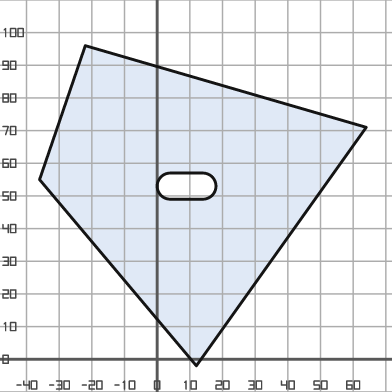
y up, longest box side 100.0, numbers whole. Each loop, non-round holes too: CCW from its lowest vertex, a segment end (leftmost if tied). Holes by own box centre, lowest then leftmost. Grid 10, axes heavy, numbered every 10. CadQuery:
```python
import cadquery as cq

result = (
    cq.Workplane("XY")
    .moveTo(12.0, -2.0)
    .lineTo(64.0, 71.0)
    .lineTo(-22.0, 96.0)
    .lineTo(-36.0, 55.0)
    .close()
    .moveTo(4.0, 49.0)
    .lineTo(14.0, 49.0)
    .threePointArc((18.0, 53.0), (14.0, 57.0))
    .lineTo(4.0, 57.0)
    .threePointArc((0.0, 53.0), (4.0, 49.0))
    .close()
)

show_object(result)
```